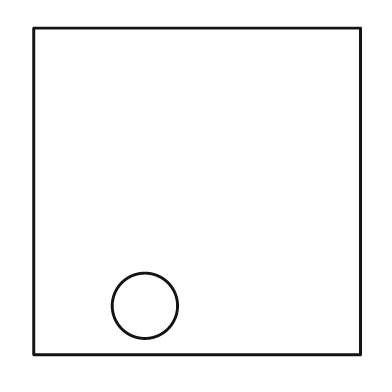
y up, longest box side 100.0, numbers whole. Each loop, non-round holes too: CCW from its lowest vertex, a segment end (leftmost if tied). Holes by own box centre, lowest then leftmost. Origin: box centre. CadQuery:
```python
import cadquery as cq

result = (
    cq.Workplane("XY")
    .moveTo(-50.0, -50.0)
    .lineTo(50.0, -50.0)
    .lineTo(50.0, 50.0)
    .lineTo(-50.0, 50.0)
    .close()
    .moveTo(-16.0, -35.0)
    .circle(10.0)
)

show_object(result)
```